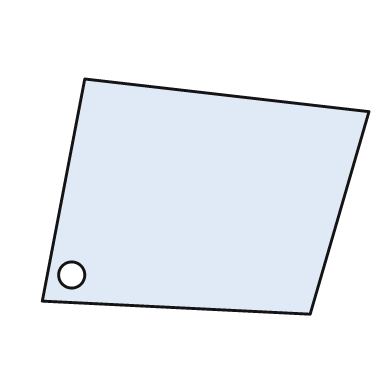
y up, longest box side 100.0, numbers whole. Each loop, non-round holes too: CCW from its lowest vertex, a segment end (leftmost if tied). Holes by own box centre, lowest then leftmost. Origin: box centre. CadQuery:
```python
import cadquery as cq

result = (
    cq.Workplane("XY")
    .moveTo(32.0, -36.0)
    .lineTo(50.0, 26.0)
    .lineTo(-37.0, 36.0)
    .lineTo(-50.0, -32.0)
    .close()
    .moveTo(-41.0, -24.0)
    .circle(4.0)
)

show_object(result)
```